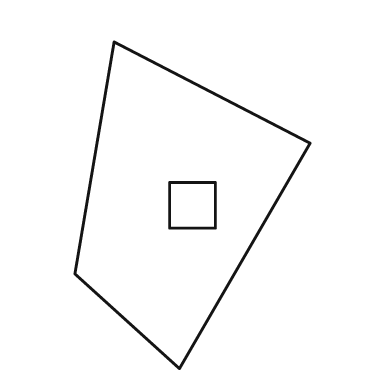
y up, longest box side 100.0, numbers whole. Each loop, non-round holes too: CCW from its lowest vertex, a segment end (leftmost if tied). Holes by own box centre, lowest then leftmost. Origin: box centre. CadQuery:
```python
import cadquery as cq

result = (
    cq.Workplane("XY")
    .moveTo(-4.0, -50.0)
    .lineTo(36.0, 19.0)
    .lineTo(-24.0, 50.0)
    .lineTo(-36.0, -21.0)
    .close()
    .moveTo(-7.0, -7.0)
    .lineTo(7.0, -7.0)
    .lineTo(7.0, 7.0)
    .lineTo(-7.0, 7.0)
    .close()
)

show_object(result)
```